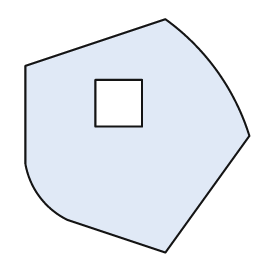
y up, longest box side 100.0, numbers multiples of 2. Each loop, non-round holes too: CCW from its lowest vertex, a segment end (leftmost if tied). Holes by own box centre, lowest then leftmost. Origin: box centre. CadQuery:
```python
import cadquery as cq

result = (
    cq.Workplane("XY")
    .moveTo(12.0, -50.0)
    .lineTo(48.0, 0.0)
    .threePointArc((34.0, 28.0), (12.0, 50.0))
    .lineTo(-48.0, 30.0)
    .lineTo(-48.0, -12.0)
    .threePointArc((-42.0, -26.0), (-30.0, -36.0))
    .close()
    .moveTo(-18.0, 4.0)
    .lineTo(2.0, 4.0)
    .lineTo(2.0, 24.0)
    .lineTo(-18.0, 24.0)
    .close()
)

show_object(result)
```